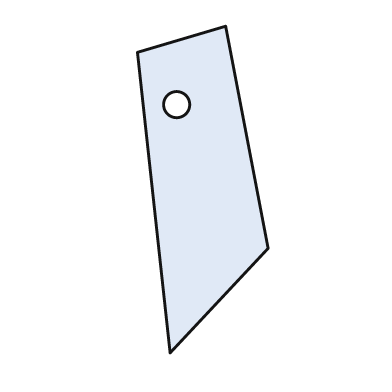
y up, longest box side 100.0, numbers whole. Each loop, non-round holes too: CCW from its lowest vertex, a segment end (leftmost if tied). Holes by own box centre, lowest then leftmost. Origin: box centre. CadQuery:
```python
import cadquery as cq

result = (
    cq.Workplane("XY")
    .moveTo(-10.0, -50.0)
    .lineTo(20.0, -18.0)
    .lineTo(7.0, 50.0)
    .lineTo(-20.0, 42.0)
    .close()
    .moveTo(-8.0, 26.0)
    .circle(4.0)
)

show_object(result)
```